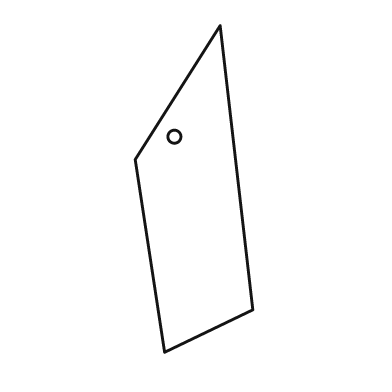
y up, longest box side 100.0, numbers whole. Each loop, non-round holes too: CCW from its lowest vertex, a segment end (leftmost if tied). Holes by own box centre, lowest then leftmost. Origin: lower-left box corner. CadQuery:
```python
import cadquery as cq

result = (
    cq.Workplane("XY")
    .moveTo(9.0, 0.0)
    .lineTo(36.0, 13.0)
    .lineTo(26.0, 100.0)
    .lineTo(0.0, 59.0)
    .close()
    .moveTo(12.0, 66.0)
    .circle(2.0)
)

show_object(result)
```